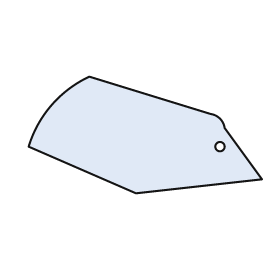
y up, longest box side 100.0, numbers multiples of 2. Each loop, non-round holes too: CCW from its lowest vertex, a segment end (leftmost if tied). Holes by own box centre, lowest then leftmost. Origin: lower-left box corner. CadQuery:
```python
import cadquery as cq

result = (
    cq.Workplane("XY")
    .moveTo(46.0, 0.0)
    .lineTo(100.0, 6.0)
    .lineTo(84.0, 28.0)
    .threePointArc((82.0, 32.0), (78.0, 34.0))
    .lineTo(26.0, 50.0)
    .threePointArc((10.0, 38.0), (0.0, 20.0))
    .close()
    .moveTo(82.0, 20.0)
    .circle(2.0)
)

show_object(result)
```